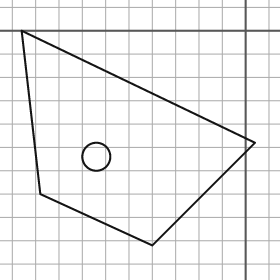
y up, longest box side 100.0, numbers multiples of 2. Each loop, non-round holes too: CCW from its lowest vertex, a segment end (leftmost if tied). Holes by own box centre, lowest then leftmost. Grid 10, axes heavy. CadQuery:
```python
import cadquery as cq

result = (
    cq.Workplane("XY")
    .moveTo(-40.0, -92.0)
    .lineTo(4.0, -48.0)
    .lineTo(-96.0, 0.0)
    .lineTo(-88.0, -70.0)
    .close()
    .moveTo(-64.0, -54.0)
    .circle(6.0)
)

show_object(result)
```